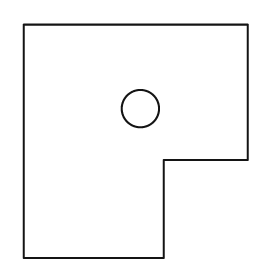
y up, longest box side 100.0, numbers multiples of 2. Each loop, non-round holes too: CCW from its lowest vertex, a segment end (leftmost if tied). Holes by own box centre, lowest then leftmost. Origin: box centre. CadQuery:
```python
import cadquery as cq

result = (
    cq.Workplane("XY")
    .moveTo(-48.0, -50.0)
    .lineTo(12.0, -50.0)
    .lineTo(12.0, -8.0)
    .lineTo(48.0, -8.0)
    .lineTo(48.0, 50.0)
    .lineTo(-48.0, 50.0)
    .close()
    .moveTo(2.0, 14.0)
    .circle(8.0)
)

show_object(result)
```